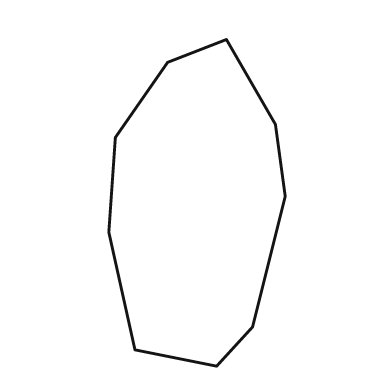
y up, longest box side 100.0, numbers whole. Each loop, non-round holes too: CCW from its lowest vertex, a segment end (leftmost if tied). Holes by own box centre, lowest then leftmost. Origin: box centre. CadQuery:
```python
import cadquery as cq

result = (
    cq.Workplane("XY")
    .moveTo(6.0, -50.0)
    .lineTo(17.0, -38.0)
    .lineTo(27.0, 2.0)
    .lineTo(24.0, 24.0)
    .lineTo(9.0, 50.0)
    .lineTo(-9.0, 43.0)
    .lineTo(-25.0, 20.0)
    .lineTo(-27.0, -9.0)
    .lineTo(-19.0, -45.0)
    .close()
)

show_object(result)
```